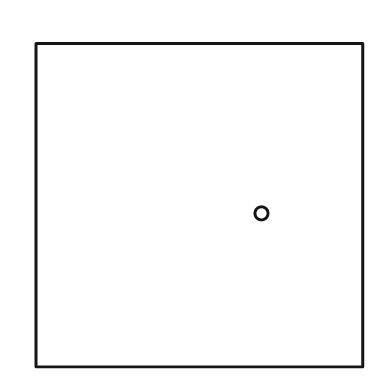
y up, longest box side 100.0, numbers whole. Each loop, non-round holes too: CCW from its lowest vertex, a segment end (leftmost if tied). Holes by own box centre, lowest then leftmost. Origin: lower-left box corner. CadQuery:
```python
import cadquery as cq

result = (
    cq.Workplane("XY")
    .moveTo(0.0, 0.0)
    .lineTo(100.0, 0.0)
    .lineTo(100.0, 99.0)
    .lineTo(0.0, 99.0)
    .close()
    .moveTo(69.0, 47.0)
    .circle(2.0)
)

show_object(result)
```